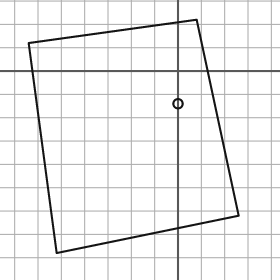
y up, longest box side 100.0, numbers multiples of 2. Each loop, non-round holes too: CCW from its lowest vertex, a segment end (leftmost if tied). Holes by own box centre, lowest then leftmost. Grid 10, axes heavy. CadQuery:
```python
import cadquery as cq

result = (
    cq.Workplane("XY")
    .moveTo(-52.0, -78.0)
    .lineTo(26.0, -62.0)
    .lineTo(8.0, 22.0)
    .lineTo(-64.0, 12.0)
    .close()
    .moveTo(0.0, -14.0)
    .circle(2.0)
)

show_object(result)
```